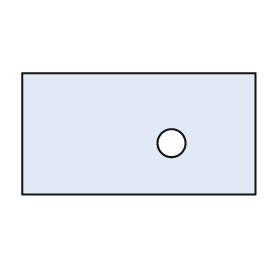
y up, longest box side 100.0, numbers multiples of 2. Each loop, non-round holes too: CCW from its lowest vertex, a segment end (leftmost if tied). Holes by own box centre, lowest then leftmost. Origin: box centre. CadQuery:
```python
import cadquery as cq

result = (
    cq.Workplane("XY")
    .moveTo(-50.0, -26.0)
    .lineTo(50.0, -26.0)
    .lineTo(50.0, 26.0)
    .lineTo(-50.0, 26.0)
    .close()
    .moveTo(14.0, -4.0)
    .circle(6.0)
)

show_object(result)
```